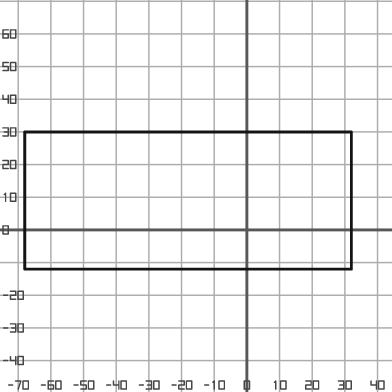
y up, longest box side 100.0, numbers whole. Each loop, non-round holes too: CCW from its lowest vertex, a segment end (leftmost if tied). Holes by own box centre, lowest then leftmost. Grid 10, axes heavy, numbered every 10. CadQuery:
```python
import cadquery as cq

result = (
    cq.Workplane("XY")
    .moveTo(-68.0, -12.0)
    .lineTo(32.0, -12.0)
    .lineTo(32.0, 30.0)
    .lineTo(-68.0, 30.0)
    .close()
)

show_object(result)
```